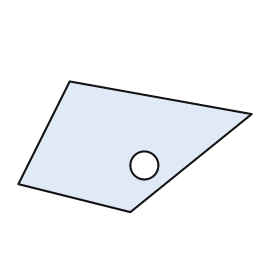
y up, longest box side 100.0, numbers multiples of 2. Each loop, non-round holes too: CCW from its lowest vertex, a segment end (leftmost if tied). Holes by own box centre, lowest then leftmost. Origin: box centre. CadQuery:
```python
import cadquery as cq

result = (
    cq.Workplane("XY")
    .moveTo(-2.0, -28.0)
    .lineTo(50.0, 14.0)
    .lineTo(-28.0, 28.0)
    .lineTo(-50.0, -16.0)
    .close()
    .moveTo(4.0, -8.0)
    .circle(6.0)
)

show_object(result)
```